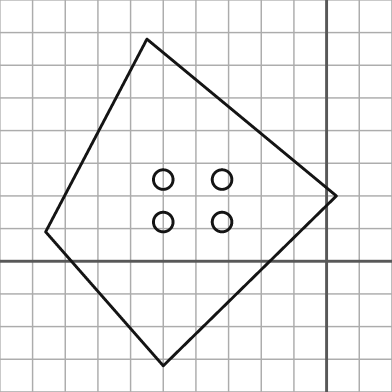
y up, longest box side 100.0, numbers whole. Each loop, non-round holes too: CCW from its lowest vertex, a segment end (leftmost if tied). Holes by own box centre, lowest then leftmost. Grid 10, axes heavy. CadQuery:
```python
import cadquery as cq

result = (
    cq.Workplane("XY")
    .moveTo(-50.0, -32.0)
    .lineTo(3.0, 20.0)
    .lineTo(-55.0, 68.0)
    .lineTo(-86.0, 9.0)
    .close()
    .moveTo(-50.0, 12.0)
    .circle(3.0)
    .moveTo(-32.0, 12.0)
    .circle(3.0)
    .moveTo(-50.0, 25.0)
    .circle(3.0)
    .moveTo(-32.0, 25.0)
    .circle(3.0)
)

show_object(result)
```